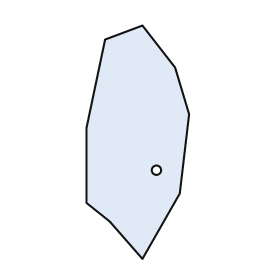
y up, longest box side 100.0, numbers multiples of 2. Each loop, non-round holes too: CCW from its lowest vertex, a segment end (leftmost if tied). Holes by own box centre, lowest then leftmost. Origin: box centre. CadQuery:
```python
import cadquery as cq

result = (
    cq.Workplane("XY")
    .moveTo(2.0, -50.0)
    .lineTo(18.0, -22.0)
    .lineTo(22.0, 12.0)
    .lineTo(16.0, 32.0)
    .lineTo(2.0, 50.0)
    .lineTo(-14.0, 44.0)
    .lineTo(-22.0, 6.0)
    .lineTo(-22.0, -26.0)
    .lineTo(-12.0, -34.0)
    .close()
    .moveTo(8.0, -12.0)
    .circle(2.0)
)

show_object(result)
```